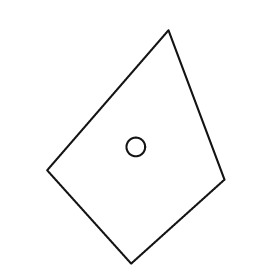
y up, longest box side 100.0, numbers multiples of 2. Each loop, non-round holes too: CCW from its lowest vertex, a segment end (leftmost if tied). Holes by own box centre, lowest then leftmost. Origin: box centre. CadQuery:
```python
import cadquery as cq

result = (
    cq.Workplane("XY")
    .moveTo(-2.0, -50.0)
    .lineTo(38.0, -14.0)
    .lineTo(14.0, 50.0)
    .lineTo(-38.0, -10.0)
    .close()
    .moveTo(0.0, 0.0)
    .circle(4.0)
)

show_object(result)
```